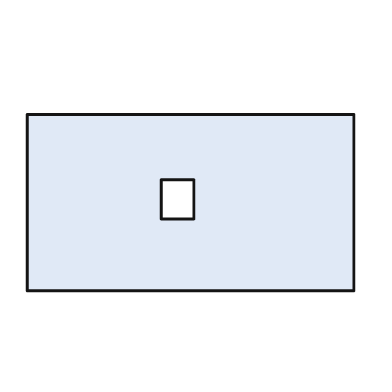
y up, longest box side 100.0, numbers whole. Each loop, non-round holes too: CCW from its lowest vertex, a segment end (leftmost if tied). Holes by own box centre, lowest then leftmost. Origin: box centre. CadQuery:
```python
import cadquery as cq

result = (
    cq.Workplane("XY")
    .moveTo(-50.0, -27.0)
    .lineTo(50.0, -27.0)
    .lineTo(50.0, 27.0)
    .lineTo(-50.0, 27.0)
    .close()
    .moveTo(-9.0, -5.0)
    .lineTo(1.0, -5.0)
    .lineTo(1.0, 7.0)
    .lineTo(-9.0, 7.0)
    .close()
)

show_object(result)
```